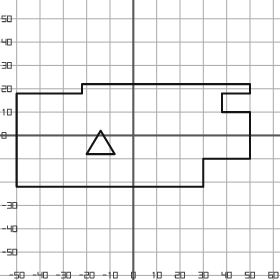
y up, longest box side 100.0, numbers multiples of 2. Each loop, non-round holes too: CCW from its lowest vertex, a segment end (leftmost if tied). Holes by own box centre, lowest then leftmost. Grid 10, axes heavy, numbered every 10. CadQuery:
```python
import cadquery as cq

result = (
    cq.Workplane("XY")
    .moveTo(-50.0, -22.0)
    .lineTo(30.0, -22.0)
    .lineTo(30.0, -10.0)
    .lineTo(50.0, -10.0)
    .lineTo(50.0, 10.0)
    .lineTo(38.0, 10.0)
    .lineTo(38.0, 18.0)
    .lineTo(50.0, 18.0)
    .lineTo(50.0, 22.0)
    .lineTo(-22.0, 22.0)
    .lineTo(-22.0, 18.0)
    .lineTo(-50.0, 18.0)
    .close()
    .moveTo(-20.0, -8.0)
    .lineTo(-8.0, -8.0)
    .lineTo(-14.0, 2.0)
    .close()
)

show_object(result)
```